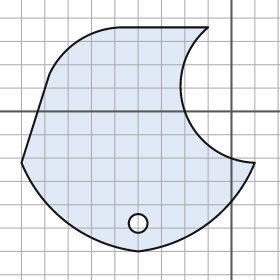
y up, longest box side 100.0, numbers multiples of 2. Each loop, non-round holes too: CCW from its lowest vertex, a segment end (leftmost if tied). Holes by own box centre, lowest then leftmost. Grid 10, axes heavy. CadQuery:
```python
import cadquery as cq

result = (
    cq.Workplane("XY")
    .moveTo(-40.0, -60.0)
    .threePointArc((-10.0, -48.0), (10.0, -22.0))
    .threePointArc((-20.0, 0.0), (-10.0, 36.0))
    .lineTo(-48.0, 36.0)
    .threePointArc((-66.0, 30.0), (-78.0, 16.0))
    .lineTo(-90.0, -22.0)
    .threePointArc((-70.0, -48.0), (-40.0, -60.0))
    .close()
    .moveTo(-40.0, -48.0)
    .circle(4.0)
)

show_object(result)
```